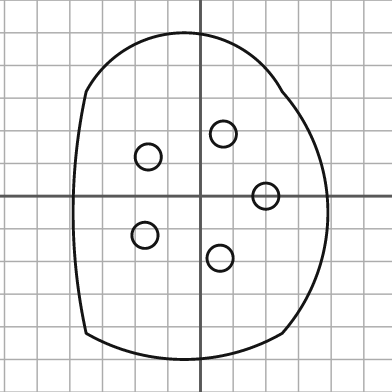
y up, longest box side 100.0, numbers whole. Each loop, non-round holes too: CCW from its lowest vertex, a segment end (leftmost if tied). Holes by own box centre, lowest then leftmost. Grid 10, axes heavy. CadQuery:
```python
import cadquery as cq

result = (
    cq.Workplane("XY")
    .moveTo(-35.0, -42.0)
    .threePointArc((-5.0, -50.0), (25.0, -42.0))
    .threePointArc((39.0, -5.0), (25.0, 32.0))
    .threePointArc((-5.0, 50.0), (-35.0, 32.0))
    .threePointArc((-39.0, -5.0), (-35.0, -42.0))
    .close()
    .moveTo(6.0, -19.0)
    .circle(4.0)
    .moveTo(-17.0, -12.0)
    .circle(4.0)
    .moveTo(20.0, 0.0)
    .circle(4.0)
    .moveTo(-16.0, 12.0)
    .circle(4.0)
    .moveTo(7.0, 19.0)
    .circle(4.0)
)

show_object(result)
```